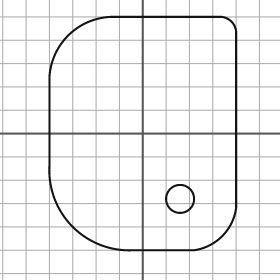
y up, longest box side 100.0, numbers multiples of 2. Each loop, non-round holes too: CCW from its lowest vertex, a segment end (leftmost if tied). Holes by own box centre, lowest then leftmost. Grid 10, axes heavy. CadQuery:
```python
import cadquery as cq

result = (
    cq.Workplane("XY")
    .moveTo(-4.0, -50.0)
    .lineTo(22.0, -50.0)
    .threePointArc((34.0, -44.0), (40.0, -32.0))
    .lineTo(40.0, 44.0)
    .threePointArc((38.0, 48.0), (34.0, 50.0))
    .lineTo(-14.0, 50.0)
    .threePointArc((-32.0, 42.0), (-40.0, 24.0))
    .lineTo(-40.0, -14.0)
    .threePointArc((-30.0, -40.0), (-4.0, -50.0))
    .close()
    .moveTo(16.0, -28.0)
    .circle(6.0)
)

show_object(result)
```